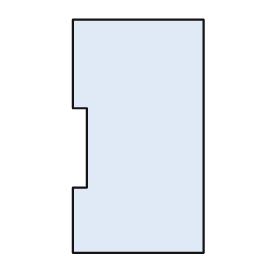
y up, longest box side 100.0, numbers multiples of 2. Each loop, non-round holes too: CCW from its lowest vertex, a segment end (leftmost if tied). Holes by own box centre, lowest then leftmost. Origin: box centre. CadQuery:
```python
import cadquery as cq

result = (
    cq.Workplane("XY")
    .moveTo(-28.0, -50.0)
    .lineTo(28.0, -50.0)
    .lineTo(28.0, 50.0)
    .lineTo(-28.0, 50.0)
    .lineTo(-28.0, 12.0)
    .lineTo(-22.0, 12.0)
    .lineTo(-22.0, -22.0)
    .lineTo(-28.0, -22.0)
    .close()
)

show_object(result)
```